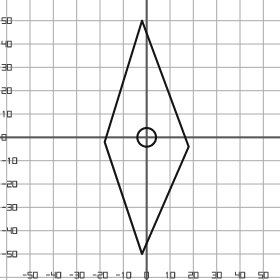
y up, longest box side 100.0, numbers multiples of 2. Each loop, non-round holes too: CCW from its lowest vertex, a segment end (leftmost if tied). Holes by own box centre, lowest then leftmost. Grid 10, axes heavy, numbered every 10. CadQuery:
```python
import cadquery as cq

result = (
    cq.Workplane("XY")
    .moveTo(-2.0, -50.0)
    .lineTo(18.0, -4.0)
    .lineTo(-2.0, 50.0)
    .lineTo(-18.0, -2.0)
    .close()
    .moveTo(0.0, 0.0)
    .circle(4.0)
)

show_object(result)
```